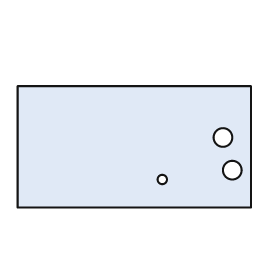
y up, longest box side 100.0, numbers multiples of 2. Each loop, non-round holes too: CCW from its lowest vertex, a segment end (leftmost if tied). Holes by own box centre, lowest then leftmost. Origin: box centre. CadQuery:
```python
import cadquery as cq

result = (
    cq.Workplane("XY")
    .moveTo(-50.0, -26.0)
    .lineTo(50.0, -26.0)
    .lineTo(50.0, 26.0)
    .lineTo(-50.0, 26.0)
    .close()
    .moveTo(12.0, -14.0)
    .circle(2.0)
    .moveTo(42.0, -10.0)
    .circle(4.0)
    .moveTo(38.0, 4.0)
    .circle(4.0)
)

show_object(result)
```